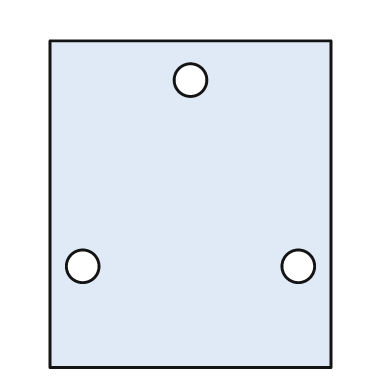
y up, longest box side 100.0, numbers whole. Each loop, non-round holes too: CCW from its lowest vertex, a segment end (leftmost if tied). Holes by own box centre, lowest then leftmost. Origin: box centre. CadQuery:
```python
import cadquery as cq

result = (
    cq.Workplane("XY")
    .moveTo(-43.0, -50.0)
    .lineTo(43.0, -50.0)
    .lineTo(43.0, 50.0)
    .lineTo(-43.0, 50.0)
    .close()
    .moveTo(-33.0, -19.0)
    .circle(5.0)
    .moveTo(33.0, -19.0)
    .circle(5.0)
    .moveTo(0.0, 38.0)
    .circle(5.0)
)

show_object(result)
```